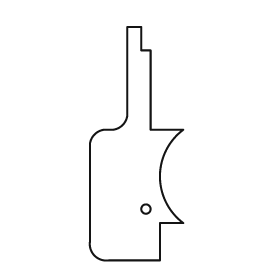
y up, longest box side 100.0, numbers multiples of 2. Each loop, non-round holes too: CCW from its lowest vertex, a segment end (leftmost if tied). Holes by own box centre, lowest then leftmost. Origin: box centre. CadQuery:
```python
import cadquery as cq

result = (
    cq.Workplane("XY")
    .moveTo(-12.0, -50.0)
    .lineTo(10.0, -50.0)
    .lineTo(10.0, -34.0)
    .lineTo(20.0, -34.0)
    .threePointArc((10.0, -14.0), (20.0, 6.0))
    .lineTo(6.0, 6.0)
    .lineTo(6.0, 40.0)
    .lineTo(2.0, 40.0)
    .lineTo(2.0, 50.0)
    .lineTo(-4.0, 50.0)
    .lineTo(-4.0, 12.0)
    .threePointArc((-6.0, 8.0), (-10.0, 6.0))
    .lineTo(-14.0, 6.0)
    .threePointArc((-18.0, 4.0), (-20.0, 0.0))
    .lineTo(-20.0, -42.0)
    .threePointArc((-18.0, -48.0), (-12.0, -50.0))
    .close()
    .moveTo(4.0, -28.0)
    .circle(2.0)
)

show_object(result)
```